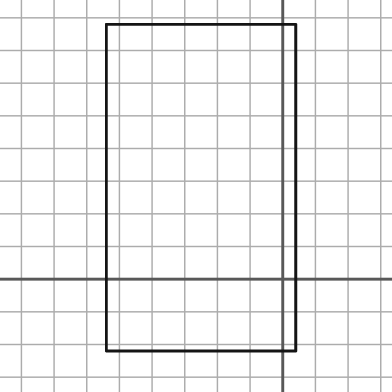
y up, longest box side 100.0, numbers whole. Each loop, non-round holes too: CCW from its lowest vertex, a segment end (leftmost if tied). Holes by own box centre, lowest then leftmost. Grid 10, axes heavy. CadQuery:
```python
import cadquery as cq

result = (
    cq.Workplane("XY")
    .moveTo(-54.0, -22.0)
    .lineTo(4.0, -22.0)
    .lineTo(4.0, 78.0)
    .lineTo(-54.0, 78.0)
    .close()
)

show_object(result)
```